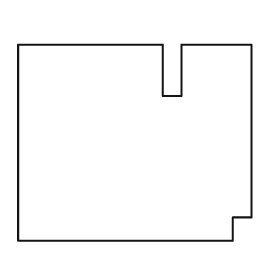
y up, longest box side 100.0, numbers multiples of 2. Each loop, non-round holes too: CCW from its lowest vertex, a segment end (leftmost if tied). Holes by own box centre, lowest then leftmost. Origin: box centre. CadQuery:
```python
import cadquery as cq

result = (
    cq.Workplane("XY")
    .moveTo(-50.0, -42.0)
    .lineTo(42.0, -42.0)
    .lineTo(42.0, -32.0)
    .lineTo(50.0, -32.0)
    .lineTo(50.0, 42.0)
    .lineTo(20.0, 42.0)
    .lineTo(20.0, 20.0)
    .lineTo(12.0, 20.0)
    .lineTo(12.0, 42.0)
    .lineTo(-50.0, 42.0)
    .close()
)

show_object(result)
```